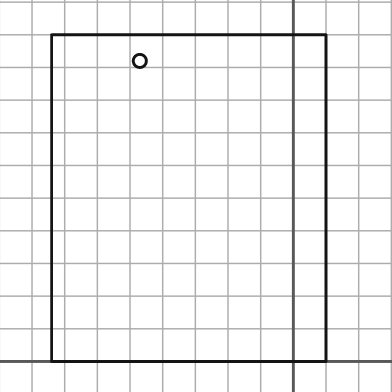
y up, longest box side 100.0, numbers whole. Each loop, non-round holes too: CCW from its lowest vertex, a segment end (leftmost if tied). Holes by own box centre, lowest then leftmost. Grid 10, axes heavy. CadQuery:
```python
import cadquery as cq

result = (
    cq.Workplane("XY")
    .moveTo(-74.0, 0.0)
    .lineTo(10.0, 0.0)
    .lineTo(10.0, 100.0)
    .lineTo(-74.0, 100.0)
    .close()
    .moveTo(-47.0, 92.0)
    .circle(2.0)
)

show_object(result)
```